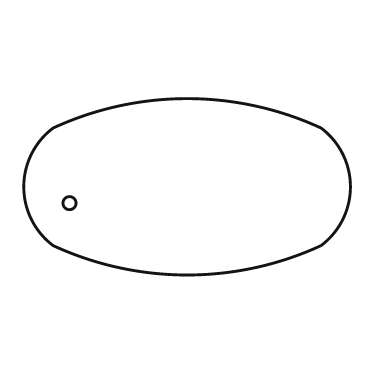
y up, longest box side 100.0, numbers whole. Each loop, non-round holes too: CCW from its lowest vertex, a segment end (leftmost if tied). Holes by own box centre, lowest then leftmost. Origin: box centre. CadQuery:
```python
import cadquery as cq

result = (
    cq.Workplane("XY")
    .moveTo(-41.0, -18.0)
    .threePointArc((0.0, -27.0), (41.0, -18.0))
    .threePointArc((50.0, 0.0), (41.0, 18.0))
    .threePointArc((0.0, 27.0), (-41.0, 18.0))
    .threePointArc((-50.0, 0.0), (-41.0, -18.0))
    .close()
    .moveTo(-36.0, -5.0)
    .circle(2.0)
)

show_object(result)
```